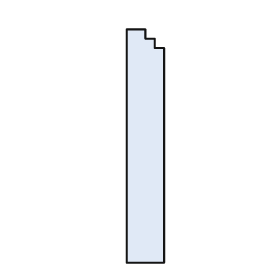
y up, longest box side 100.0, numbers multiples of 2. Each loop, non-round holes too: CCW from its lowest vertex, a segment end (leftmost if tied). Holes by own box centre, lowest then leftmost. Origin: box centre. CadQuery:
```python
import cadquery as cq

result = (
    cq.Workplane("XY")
    .moveTo(-8.0, -50.0)
    .lineTo(8.0, -50.0)
    .lineTo(8.0, 42.0)
    .lineTo(4.0, 42.0)
    .lineTo(4.0, 46.0)
    .lineTo(0.0, 46.0)
    .lineTo(0.0, 50.0)
    .lineTo(-8.0, 50.0)
    .close()
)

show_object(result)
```